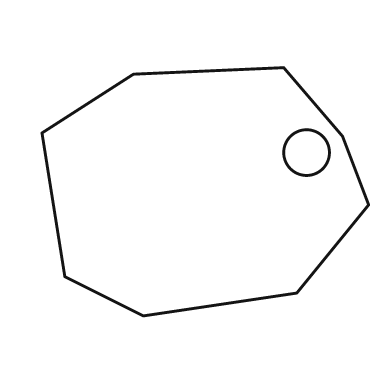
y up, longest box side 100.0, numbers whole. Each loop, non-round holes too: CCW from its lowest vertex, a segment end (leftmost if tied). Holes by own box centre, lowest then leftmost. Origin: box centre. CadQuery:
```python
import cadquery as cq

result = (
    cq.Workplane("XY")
    .moveTo(-19.0, -38.0)
    .lineTo(28.0, -31.0)
    .lineTo(50.0, -4.0)
    .lineTo(42.0, 17.0)
    .lineTo(24.0, 38.0)
    .lineTo(-22.0, 36.0)
    .lineTo(-50.0, 18.0)
    .lineTo(-43.0, -26.0)
    .close()
    .moveTo(31.0, 12.0)
    .circle(7.0)
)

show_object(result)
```